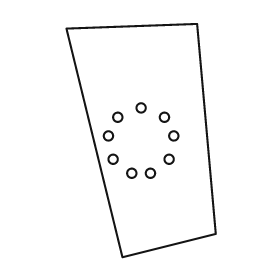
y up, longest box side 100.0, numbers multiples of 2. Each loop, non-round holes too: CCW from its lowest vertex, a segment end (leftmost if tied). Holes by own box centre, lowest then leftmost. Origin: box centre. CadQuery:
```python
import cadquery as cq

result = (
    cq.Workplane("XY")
    .moveTo(-8.0, -50.0)
    .lineTo(32.0, -40.0)
    .lineTo(24.0, 50.0)
    .lineTo(-32.0, 48.0)
    .close()
    .moveTo(-4.0, -14.0)
    .circle(2.0)
    .moveTo(4.0, -14.0)
    .circle(2.0)
    .moveTo(-12.0, -8.0)
    .circle(2.0)
    .moveTo(12.0, -8.0)
    .circle(2.0)
    .moveTo(-14.0, 2.0)
    .circle(2.0)
    .moveTo(14.0, 2.0)
    .circle(2.0)
    .moveTo(-10.0, 10.0)
    .circle(2.0)
    .moveTo(10.0, 10.0)
    .circle(2.0)
    .moveTo(0.0, 14.0)
    .circle(2.0)
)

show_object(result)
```